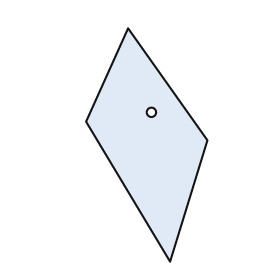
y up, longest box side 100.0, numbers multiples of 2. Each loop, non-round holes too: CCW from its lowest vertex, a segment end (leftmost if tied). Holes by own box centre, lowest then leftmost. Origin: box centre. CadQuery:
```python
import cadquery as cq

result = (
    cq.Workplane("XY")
    .moveTo(10.0, -50.0)
    .lineTo(26.0, 2.0)
    .lineTo(-8.0, 50.0)
    .lineTo(-26.0, 10.0)
    .close()
    .moveTo(2.0, 14.0)
    .circle(2.0)
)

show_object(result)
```